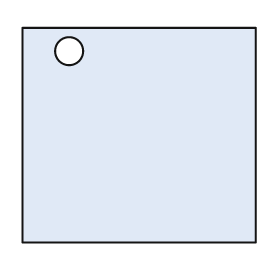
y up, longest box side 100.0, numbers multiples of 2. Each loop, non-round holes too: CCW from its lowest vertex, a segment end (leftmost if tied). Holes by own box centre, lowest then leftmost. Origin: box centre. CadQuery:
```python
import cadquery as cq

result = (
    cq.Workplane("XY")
    .moveTo(-50.0, -46.0)
    .lineTo(50.0, -46.0)
    .lineTo(50.0, 46.0)
    .lineTo(-50.0, 46.0)
    .close()
    .moveTo(-30.0, 36.0)
    .circle(6.0)
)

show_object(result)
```